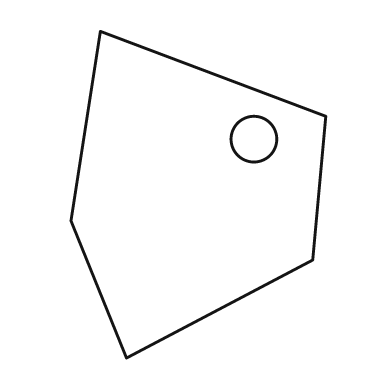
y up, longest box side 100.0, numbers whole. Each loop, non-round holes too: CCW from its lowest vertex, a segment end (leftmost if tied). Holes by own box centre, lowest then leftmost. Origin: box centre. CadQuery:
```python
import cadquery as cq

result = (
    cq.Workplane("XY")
    .moveTo(-22.0, -50.0)
    .lineTo(35.0, -20.0)
    .lineTo(39.0, 24.0)
    .lineTo(-30.0, 50.0)
    .lineTo(-39.0, -8.0)
    .close()
    .moveTo(17.0, 17.0)
    .circle(7.0)
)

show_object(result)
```